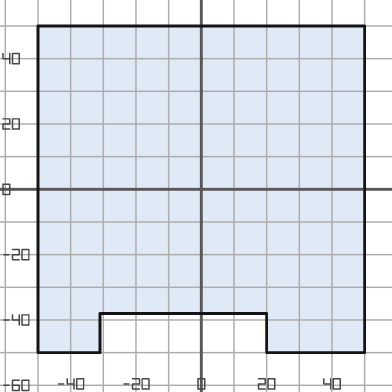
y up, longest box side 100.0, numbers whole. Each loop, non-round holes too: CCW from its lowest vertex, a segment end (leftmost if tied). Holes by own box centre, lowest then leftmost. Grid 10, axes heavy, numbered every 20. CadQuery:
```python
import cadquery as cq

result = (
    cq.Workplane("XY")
    .moveTo(-50.0, -50.0)
    .lineTo(-31.0, -50.0)
    .lineTo(-31.0, -38.0)
    .lineTo(20.0, -38.0)
    .lineTo(20.0, -50.0)
    .lineTo(50.0, -50.0)
    .lineTo(50.0, 50.0)
    .lineTo(-50.0, 50.0)
    .close()
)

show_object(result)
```